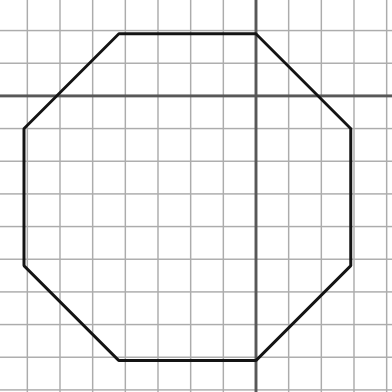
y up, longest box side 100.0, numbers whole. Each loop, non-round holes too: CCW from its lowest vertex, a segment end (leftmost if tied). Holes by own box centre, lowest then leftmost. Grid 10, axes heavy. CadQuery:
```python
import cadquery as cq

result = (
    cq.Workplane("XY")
    .moveTo(-42.0, -81.0)
    .lineTo(0.0, -81.0)
    .lineTo(29.0, -52.0)
    .lineTo(29.0, -10.0)
    .lineTo(0.0, 19.0)
    .lineTo(-42.0, 19.0)
    .lineTo(-71.0, -10.0)
    .lineTo(-71.0, -52.0)
    .close()
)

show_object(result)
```